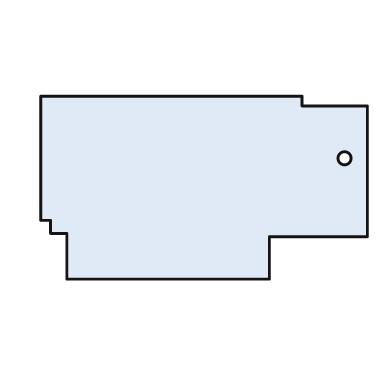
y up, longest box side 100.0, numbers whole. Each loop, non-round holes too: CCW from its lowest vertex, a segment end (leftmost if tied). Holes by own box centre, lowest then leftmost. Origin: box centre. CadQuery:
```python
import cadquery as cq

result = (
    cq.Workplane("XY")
    .moveTo(-42.0, -28.0)
    .lineTo(20.0, -28.0)
    .lineTo(20.0, -15.0)
    .lineTo(50.0, -15.0)
    .lineTo(50.0, 25.0)
    .lineTo(30.0, 25.0)
    .lineTo(30.0, 28.0)
    .lineTo(-50.0, 28.0)
    .lineTo(-50.0, -10.0)
    .lineTo(-47.0, -10.0)
    .lineTo(-47.0, -14.0)
    .lineTo(-42.0, -14.0)
    .close()
    .moveTo(43.0, 9.0)
    .circle(2.0)
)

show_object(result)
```